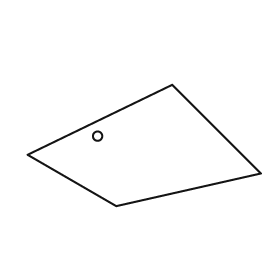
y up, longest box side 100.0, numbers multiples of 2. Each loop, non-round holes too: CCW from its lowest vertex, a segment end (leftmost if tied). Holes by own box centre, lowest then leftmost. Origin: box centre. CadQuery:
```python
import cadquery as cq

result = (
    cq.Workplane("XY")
    .moveTo(-12.0, -26.0)
    .lineTo(50.0, -12.0)
    .lineTo(12.0, 26.0)
    .lineTo(-50.0, -4.0)
    .close()
    .moveTo(-20.0, 4.0)
    .circle(2.0)
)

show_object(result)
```